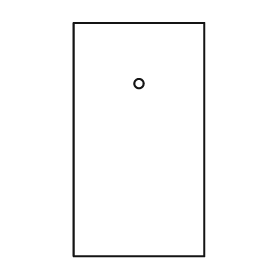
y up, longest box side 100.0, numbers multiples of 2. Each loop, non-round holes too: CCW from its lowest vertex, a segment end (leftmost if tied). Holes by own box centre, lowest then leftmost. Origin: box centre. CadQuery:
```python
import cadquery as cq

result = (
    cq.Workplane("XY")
    .moveTo(-28.0, -50.0)
    .lineTo(28.0, -50.0)
    .lineTo(28.0, 50.0)
    .lineTo(-28.0, 50.0)
    .close()
    .moveTo(0.0, 24.0)
    .circle(2.0)
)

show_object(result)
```